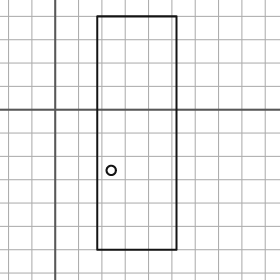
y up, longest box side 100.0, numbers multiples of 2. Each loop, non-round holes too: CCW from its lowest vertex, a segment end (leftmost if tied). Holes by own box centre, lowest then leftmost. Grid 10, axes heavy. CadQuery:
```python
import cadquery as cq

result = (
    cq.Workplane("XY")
    .moveTo(18.0, -60.0)
    .lineTo(52.0, -60.0)
    .lineTo(52.0, 40.0)
    .lineTo(18.0, 40.0)
    .close()
    .moveTo(24.0, -26.0)
    .circle(2.0)
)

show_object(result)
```